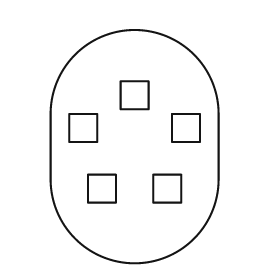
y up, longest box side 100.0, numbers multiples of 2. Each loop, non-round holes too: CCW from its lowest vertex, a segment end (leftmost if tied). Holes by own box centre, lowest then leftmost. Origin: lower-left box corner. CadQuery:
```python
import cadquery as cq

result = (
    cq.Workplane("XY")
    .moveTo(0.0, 36.0)
    .threePointArc((36.0, 0.0), (72.0, 36.0))
    .lineTo(72.0, 64.0)
    .threePointArc((36.0, 100.0), (0.0, 64.0))
    .close()
    .moveTo(16.0, 26.0)
    .lineTo(28.0, 26.0)
    .lineTo(28.0, 38.0)
    .lineTo(16.0, 38.0)
    .close()
    .moveTo(44.0, 26.0)
    .lineTo(56.0, 26.0)
    .lineTo(56.0, 38.0)
    .lineTo(44.0, 38.0)
    .close()
    .moveTo(8.0, 52.0)
    .lineTo(20.0, 52.0)
    .lineTo(20.0, 64.0)
    .lineTo(8.0, 64.0)
    .close()
    .moveTo(52.0, 52.0)
    .lineTo(64.0, 52.0)
    .lineTo(64.0, 64.0)
    .lineTo(52.0, 64.0)
    .close()
    .moveTo(30.0, 66.0)
    .lineTo(42.0, 66.0)
    .lineTo(42.0, 78.0)
    .lineTo(30.0, 78.0)
    .close()
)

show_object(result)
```